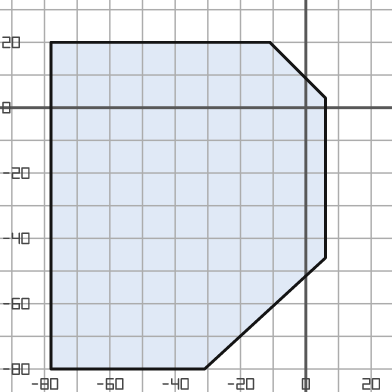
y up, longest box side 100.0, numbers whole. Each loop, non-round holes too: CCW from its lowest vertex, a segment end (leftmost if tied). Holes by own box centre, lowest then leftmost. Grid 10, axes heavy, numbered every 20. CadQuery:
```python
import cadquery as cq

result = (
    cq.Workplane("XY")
    .moveTo(-78.0, -80.0)
    .lineTo(-31.0, -80.0)
    .lineTo(6.0, -46.0)
    .lineTo(6.0, 3.0)
    .lineTo(-11.0, 20.0)
    .lineTo(-78.0, 20.0)
    .close()
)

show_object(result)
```